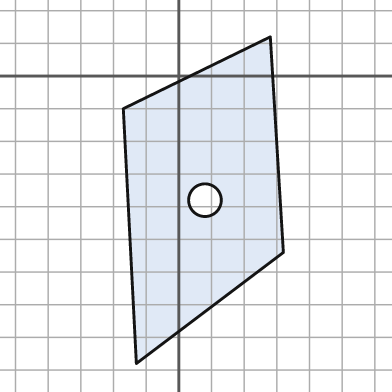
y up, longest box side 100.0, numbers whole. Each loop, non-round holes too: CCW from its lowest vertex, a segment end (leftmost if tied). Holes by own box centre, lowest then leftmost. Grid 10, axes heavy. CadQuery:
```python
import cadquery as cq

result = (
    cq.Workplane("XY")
    .moveTo(-13.0, -88.0)
    .lineTo(32.0, -54.0)
    .lineTo(28.0, 12.0)
    .lineTo(-17.0, -10.0)
    .close()
    .moveTo(8.0, -38.0)
    .circle(5.0)
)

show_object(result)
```